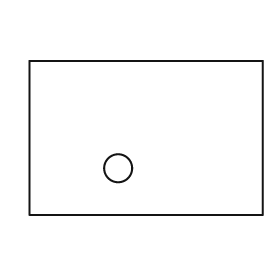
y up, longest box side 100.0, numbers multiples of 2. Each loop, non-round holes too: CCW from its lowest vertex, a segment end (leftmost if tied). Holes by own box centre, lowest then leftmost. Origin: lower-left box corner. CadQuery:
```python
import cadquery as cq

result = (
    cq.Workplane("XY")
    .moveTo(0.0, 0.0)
    .lineTo(100.0, 0.0)
    .lineTo(100.0, 66.0)
    .lineTo(0.0, 66.0)
    .close()
    .moveTo(38.0, 20.0)
    .circle(6.0)
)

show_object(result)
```